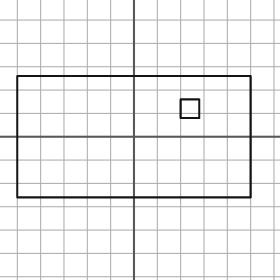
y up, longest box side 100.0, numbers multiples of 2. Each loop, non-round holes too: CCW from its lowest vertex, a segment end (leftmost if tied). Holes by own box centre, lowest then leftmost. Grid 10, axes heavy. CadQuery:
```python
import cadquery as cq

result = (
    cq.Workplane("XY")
    .moveTo(-50.0, -26.0)
    .lineTo(50.0, -26.0)
    .lineTo(50.0, 26.0)
    .lineTo(-50.0, 26.0)
    .close()
    .moveTo(20.0, 8.0)
    .lineTo(28.0, 8.0)
    .lineTo(28.0, 16.0)
    .lineTo(20.0, 16.0)
    .close()
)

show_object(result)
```